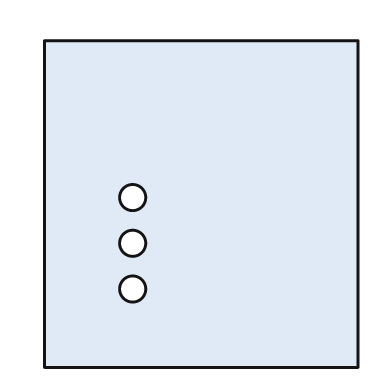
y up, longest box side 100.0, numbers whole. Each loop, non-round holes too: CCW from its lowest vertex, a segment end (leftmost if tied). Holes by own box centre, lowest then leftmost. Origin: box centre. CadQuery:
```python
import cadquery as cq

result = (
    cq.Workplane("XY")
    .moveTo(-48.0, -50.0)
    .lineTo(48.0, -50.0)
    .lineTo(48.0, 50.0)
    .lineTo(-48.0, 50.0)
    .close()
    .moveTo(-21.0, -26.0)
    .circle(4.0)
    .moveTo(-21.0, -12.0)
    .circle(4.0)
    .moveTo(-21.0, 2.0)
    .circle(4.0)
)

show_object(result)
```